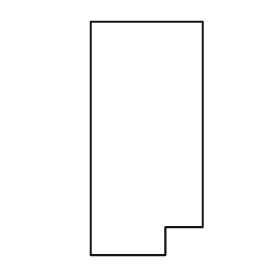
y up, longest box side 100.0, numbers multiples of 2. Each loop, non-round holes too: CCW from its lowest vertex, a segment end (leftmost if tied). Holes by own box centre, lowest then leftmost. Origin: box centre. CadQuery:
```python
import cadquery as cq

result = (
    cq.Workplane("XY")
    .moveTo(-24.0, -50.0)
    .lineTo(8.0, -50.0)
    .lineTo(8.0, -38.0)
    .lineTo(24.0, -38.0)
    .lineTo(24.0, 50.0)
    .lineTo(-24.0, 50.0)
    .close()
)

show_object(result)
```